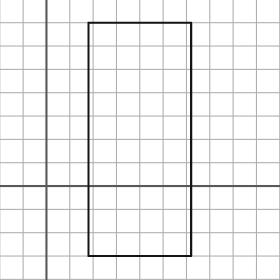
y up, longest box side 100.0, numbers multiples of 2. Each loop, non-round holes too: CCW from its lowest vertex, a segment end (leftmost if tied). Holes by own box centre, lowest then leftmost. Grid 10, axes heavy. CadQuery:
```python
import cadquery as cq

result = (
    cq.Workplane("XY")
    .moveTo(18.0, -30.0)
    .lineTo(62.0, -30.0)
    .lineTo(62.0, 70.0)
    .lineTo(18.0, 70.0)
    .close()
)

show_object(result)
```